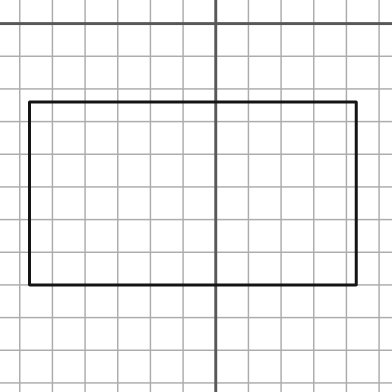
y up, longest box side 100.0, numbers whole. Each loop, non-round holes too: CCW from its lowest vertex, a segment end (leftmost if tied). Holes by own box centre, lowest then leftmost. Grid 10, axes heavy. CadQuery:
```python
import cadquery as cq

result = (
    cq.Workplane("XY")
    .moveTo(-57.0, -80.0)
    .lineTo(43.0, -80.0)
    .lineTo(43.0, -24.0)
    .lineTo(-57.0, -24.0)
    .close()
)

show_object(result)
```